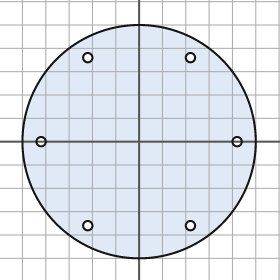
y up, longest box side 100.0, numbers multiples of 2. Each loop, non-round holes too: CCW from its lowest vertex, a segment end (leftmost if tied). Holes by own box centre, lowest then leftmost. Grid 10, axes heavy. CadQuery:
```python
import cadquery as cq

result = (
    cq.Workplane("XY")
    .moveTo(0.0, 0.0)
    .circle(50.0)
    .moveTo(-22.0, -36.0)
    .circle(2.0)
    .moveTo(22.0, -36.0)
    .circle(2.0)
    .moveTo(-42.0, 0.0)
    .circle(2.0)
    .moveTo(42.0, 0.0)
    .circle(2.0)
    .moveTo(-22.0, 36.0)
    .circle(2.0)
    .moveTo(22.0, 36.0)
    .circle(2.0)
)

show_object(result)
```